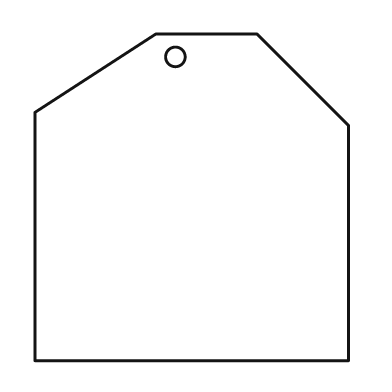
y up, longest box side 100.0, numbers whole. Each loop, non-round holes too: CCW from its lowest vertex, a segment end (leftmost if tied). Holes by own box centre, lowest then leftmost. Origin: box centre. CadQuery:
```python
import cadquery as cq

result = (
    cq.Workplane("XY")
    .moveTo(-48.0, -50.0)
    .lineTo(48.0, -50.0)
    .lineTo(48.0, 22.0)
    .lineTo(20.0, 50.0)
    .lineTo(-11.0, 50.0)
    .lineTo(-48.0, 26.0)
    .close()
    .moveTo(-5.0, 43.0)
    .circle(3.0)
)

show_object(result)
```